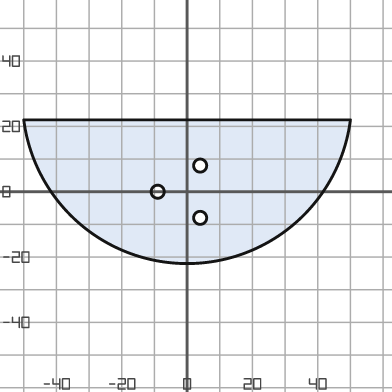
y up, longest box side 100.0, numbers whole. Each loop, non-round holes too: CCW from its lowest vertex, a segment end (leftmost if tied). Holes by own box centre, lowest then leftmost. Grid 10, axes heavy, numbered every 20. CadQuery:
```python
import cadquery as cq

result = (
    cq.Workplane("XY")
    .moveTo(-50.0, 22.0)
    .threePointArc((0.0, -22.0), (50.0, 22.0))
    .close()
    .moveTo(4.0, -8.0)
    .circle(2.0)
    .moveTo(-9.0, 0.0)
    .circle(2.0)
    .moveTo(4.0, 8.0)
    .circle(2.0)
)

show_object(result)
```